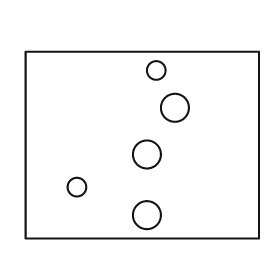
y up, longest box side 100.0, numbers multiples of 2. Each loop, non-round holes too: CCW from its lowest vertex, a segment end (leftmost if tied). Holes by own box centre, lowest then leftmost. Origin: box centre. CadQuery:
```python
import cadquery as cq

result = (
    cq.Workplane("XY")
    .moveTo(-50.0, -40.0)
    .lineTo(50.0, -40.0)
    .lineTo(50.0, 40.0)
    .lineTo(-50.0, 40.0)
    .close()
    .moveTo(2.0, -30.0)
    .circle(6.0)
    .moveTo(-28.0, -18.0)
    .circle(4.0)
    .moveTo(2.0, -4.0)
    .circle(6.0)
    .moveTo(14.0, 16.0)
    .circle(6.0)
    .moveTo(6.0, 32.0)
    .circle(4.0)
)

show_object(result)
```